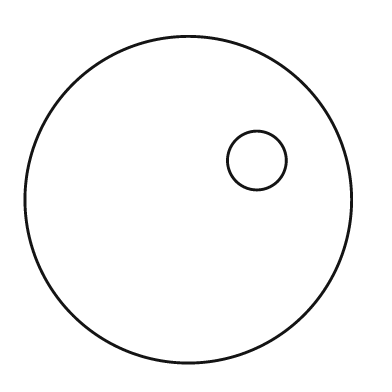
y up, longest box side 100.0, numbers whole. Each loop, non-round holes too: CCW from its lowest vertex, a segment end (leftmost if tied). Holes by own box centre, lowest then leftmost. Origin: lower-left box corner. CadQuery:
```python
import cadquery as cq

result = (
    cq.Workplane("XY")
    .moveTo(50.0, 50.0)
    .circle(50.0)
    .moveTo(71.0, 62.0)
    .circle(9.0)
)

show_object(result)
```